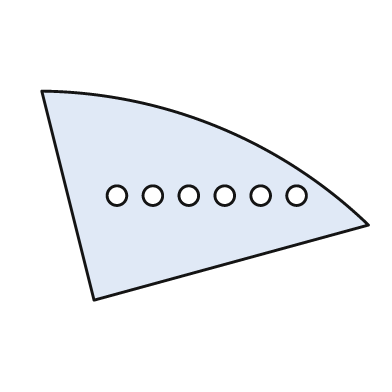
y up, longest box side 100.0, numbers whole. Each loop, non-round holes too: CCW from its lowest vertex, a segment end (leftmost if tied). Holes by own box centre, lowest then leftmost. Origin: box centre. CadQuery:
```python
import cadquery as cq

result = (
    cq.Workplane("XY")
    .moveTo(-34.0, -32.0)
    .lineTo(50.0, -9.0)
    .threePointArc((4.0, 21.0), (-50.0, 32.0))
    .close()
    .moveTo(-27.0, 0.0)
    .circle(3.0)
    .moveTo(-16.0, 0.0)
    .circle(3.0)
    .moveTo(-5.0, 0.0)
    .circle(3.0)
    .moveTo(6.0, 0.0)
    .circle(3.0)
    .moveTo(17.0, 0.0)
    .circle(3.0)
    .moveTo(28.0, 0.0)
    .circle(3.0)
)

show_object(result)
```